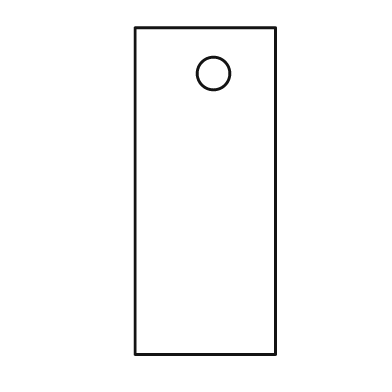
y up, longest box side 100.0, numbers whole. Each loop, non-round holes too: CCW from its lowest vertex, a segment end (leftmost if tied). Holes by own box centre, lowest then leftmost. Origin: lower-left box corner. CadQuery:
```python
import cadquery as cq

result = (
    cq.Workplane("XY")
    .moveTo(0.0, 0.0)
    .lineTo(43.0, 0.0)
    .lineTo(43.0, 100.0)
    .lineTo(0.0, 100.0)
    .close()
    .moveTo(24.0, 86.0)
    .circle(5.0)
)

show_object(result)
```